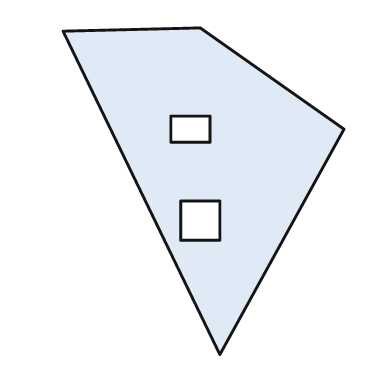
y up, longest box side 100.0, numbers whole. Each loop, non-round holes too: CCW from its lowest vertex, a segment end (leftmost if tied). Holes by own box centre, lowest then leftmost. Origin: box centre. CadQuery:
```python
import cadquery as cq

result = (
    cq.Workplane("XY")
    .moveTo(5.0, -50.0)
    .lineTo(43.0, 19.0)
    .lineTo(-1.0, 50.0)
    .lineTo(-43.0, 49.0)
    .close()
    .moveTo(-7.0, -15.0)
    .lineTo(5.0, -15.0)
    .lineTo(5.0, -3.0)
    .lineTo(-7.0, -3.0)
    .close()
    .moveTo(-10.0, 15.0)
    .lineTo(2.0, 15.0)
    .lineTo(2.0, 23.0)
    .lineTo(-10.0, 23.0)
    .close()
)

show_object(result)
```